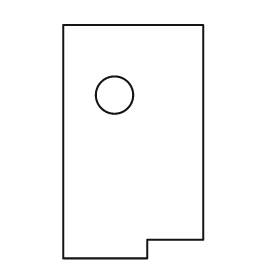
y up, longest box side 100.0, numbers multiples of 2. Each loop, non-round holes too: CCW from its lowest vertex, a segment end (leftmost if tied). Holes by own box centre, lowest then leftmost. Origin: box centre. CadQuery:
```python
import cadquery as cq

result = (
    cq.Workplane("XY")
    .moveTo(-30.0, -50.0)
    .lineTo(6.0, -50.0)
    .lineTo(6.0, -42.0)
    .lineTo(30.0, -42.0)
    .lineTo(30.0, 50.0)
    .lineTo(-30.0, 50.0)
    .close()
    .moveTo(-8.0, 20.0)
    .circle(8.0)
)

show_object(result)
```